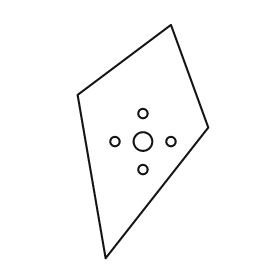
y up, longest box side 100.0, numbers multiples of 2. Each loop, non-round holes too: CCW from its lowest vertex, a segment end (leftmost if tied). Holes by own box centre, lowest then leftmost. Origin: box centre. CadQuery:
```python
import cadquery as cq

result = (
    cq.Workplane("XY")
    .moveTo(-16.0, -50.0)
    .lineTo(28.0, 6.0)
    .lineTo(12.0, 50.0)
    .lineTo(-28.0, 20.0)
    .close()
    .moveTo(0.0, -12.0)
    .circle(2.0)
    .moveTo(-12.0, 0.0)
    .circle(2.0)
    .moveTo(0.0, 0.0)
    .circle(4.0)
    .moveTo(12.0, 0.0)
    .circle(2.0)
    .moveTo(0.0, 12.0)
    .circle(2.0)
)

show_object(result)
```